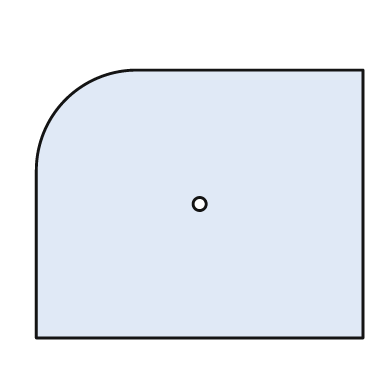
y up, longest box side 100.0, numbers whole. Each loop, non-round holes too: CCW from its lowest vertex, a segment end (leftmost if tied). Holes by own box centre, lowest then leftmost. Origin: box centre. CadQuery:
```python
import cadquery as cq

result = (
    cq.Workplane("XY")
    .moveTo(-50.0, -41.0)
    .lineTo(50.0, -41.0)
    .lineTo(50.0, 41.0)
    .lineTo(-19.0, 41.0)
    .threePointArc((-41.0, 32.0), (-50.0, 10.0))
    .close()
    .moveTo(0.0, 0.0)
    .circle(2.0)
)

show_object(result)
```